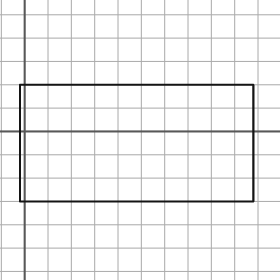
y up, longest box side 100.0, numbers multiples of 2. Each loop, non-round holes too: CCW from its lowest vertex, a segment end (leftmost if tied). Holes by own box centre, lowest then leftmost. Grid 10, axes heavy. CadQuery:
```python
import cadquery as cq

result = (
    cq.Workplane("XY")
    .moveTo(-2.0, -30.0)
    .lineTo(98.0, -30.0)
    .lineTo(98.0, 20.0)
    .lineTo(-2.0, 20.0)
    .close()
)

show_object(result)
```